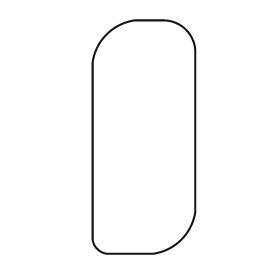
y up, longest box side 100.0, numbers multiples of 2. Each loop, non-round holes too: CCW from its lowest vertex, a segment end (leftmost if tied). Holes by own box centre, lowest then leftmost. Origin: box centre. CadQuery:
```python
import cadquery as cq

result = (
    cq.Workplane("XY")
    .moveTo(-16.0, -50.0)
    .lineTo(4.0, -50.0)
    .threePointArc((16.0, -44.0), (22.0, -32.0))
    .lineTo(22.0, 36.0)
    .threePointArc((18.0, 46.0), (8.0, 50.0))
    .lineTo(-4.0, 50.0)
    .threePointArc((-16.0, 44.0), (-22.0, 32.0))
    .lineTo(-22.0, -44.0)
    .threePointArc((-20.0, -48.0), (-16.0, -50.0))
    .close()
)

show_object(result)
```